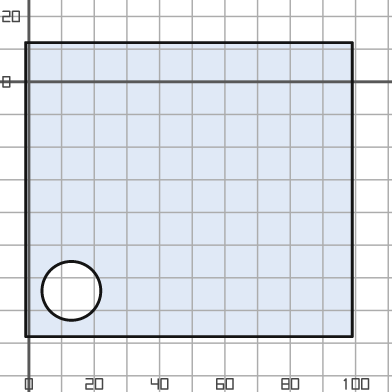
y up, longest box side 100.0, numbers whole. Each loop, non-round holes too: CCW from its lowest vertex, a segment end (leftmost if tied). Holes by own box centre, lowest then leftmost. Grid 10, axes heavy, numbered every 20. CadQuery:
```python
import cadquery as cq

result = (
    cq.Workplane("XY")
    .moveTo(-1.0, -78.0)
    .lineTo(99.0, -78.0)
    .lineTo(99.0, 12.0)
    .lineTo(-1.0, 12.0)
    .close()
    .moveTo(13.0, -64.0)
    .circle(9.0)
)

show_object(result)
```